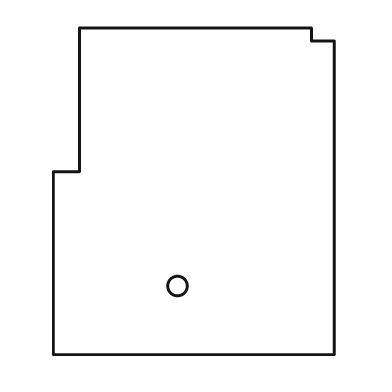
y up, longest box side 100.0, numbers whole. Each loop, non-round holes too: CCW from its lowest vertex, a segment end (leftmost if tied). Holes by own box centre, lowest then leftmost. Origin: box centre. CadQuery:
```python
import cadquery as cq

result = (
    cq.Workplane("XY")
    .moveTo(-43.0, -50.0)
    .lineTo(43.0, -50.0)
    .lineTo(43.0, 46.0)
    .lineTo(36.0, 46.0)
    .lineTo(36.0, 50.0)
    .lineTo(-35.0, 50.0)
    .lineTo(-35.0, 6.0)
    .lineTo(-43.0, 6.0)
    .close()
    .moveTo(-5.0, -29.0)
    .circle(3.0)
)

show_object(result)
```